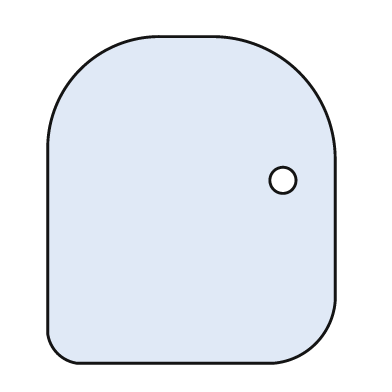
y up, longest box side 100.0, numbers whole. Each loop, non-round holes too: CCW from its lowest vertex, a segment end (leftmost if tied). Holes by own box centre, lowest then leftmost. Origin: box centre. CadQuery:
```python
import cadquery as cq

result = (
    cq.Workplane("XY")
    .moveTo(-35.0, -50.0)
    .lineTo(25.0, -50.0)
    .threePointArc((38.0, -44.0), (44.0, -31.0))
    .lineTo(44.0, 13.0)
    .threePointArc((33.0, 39.0), (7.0, 50.0))
    .lineTo(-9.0, 50.0)
    .threePointArc((-34.0, 40.0), (-44.0, 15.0))
    .lineTo(-44.0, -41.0)
    .threePointArc((-41.0, -47.0), (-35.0, -50.0))
    .close()
    .moveTo(28.0, 6.0)
    .circle(4.0)
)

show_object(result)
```